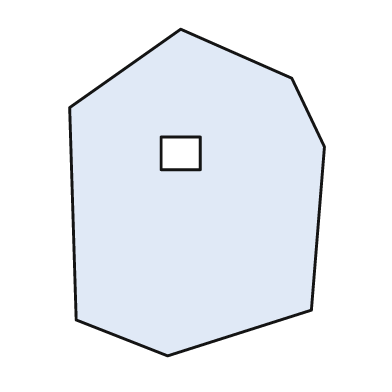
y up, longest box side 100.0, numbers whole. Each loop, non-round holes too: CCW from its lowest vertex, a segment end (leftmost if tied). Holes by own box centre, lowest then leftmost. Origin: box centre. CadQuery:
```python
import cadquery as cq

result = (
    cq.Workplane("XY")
    .moveTo(-9.0, -50.0)
    .lineTo(35.0, -36.0)
    .lineTo(39.0, 14.0)
    .lineTo(29.0, 35.0)
    .lineTo(-5.0, 50.0)
    .lineTo(-39.0, 26.0)
    .lineTo(-37.0, -39.0)
    .close()
    .moveTo(-11.0, 7.0)
    .lineTo(1.0, 7.0)
    .lineTo(1.0, 17.0)
    .lineTo(-11.0, 17.0)
    .close()
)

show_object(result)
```